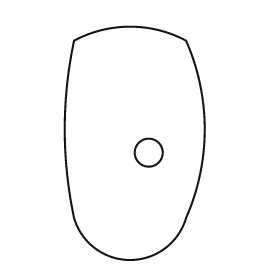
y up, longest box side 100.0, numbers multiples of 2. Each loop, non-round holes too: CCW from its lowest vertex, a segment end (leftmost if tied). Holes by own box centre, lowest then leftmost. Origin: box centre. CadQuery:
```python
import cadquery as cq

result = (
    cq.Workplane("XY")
    .moveTo(-26.0, -32.0)
    .threePointArc((-2.0, -50.0), (22.0, -32.0))
    .threePointArc((30.0, 6.0), (22.0, 44.0))
    .threePointArc((-2.0, 50.0), (-26.0, 44.0))
    .threePointArc((-30.0, 6.0), (-26.0, -32.0))
    .close()
    .moveTo(6.0, -4.0)
    .circle(6.0)
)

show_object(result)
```